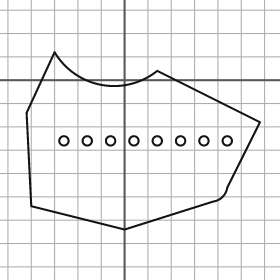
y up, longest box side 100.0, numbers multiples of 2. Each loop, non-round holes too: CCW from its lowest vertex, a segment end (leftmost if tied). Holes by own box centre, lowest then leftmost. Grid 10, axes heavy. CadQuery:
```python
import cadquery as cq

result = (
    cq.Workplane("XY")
    .moveTo(0.0, -64.0)
    .lineTo(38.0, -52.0)
    .threePointArc((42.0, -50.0), (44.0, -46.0))
    .lineTo(58.0, -18.0)
    .lineTo(14.0, 4.0)
    .threePointArc((-10.0, -2.0), (-30.0, 12.0))
    .lineTo(-42.0, -14.0)
    .lineTo(-40.0, -54.0)
    .close()
    .moveTo(-26.0, -26.0)
    .circle(2.0)
    .moveTo(-16.0, -26.0)
    .circle(2.0)
    .moveTo(-6.0, -26.0)
    .circle(2.0)
    .moveTo(4.0, -26.0)
    .circle(2.0)
    .moveTo(14.0, -26.0)
    .circle(2.0)
    .moveTo(24.0, -26.0)
    .circle(2.0)
    .moveTo(34.0, -26.0)
    .circle(2.0)
    .moveTo(44.0, -26.0)
    .circle(2.0)
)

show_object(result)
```